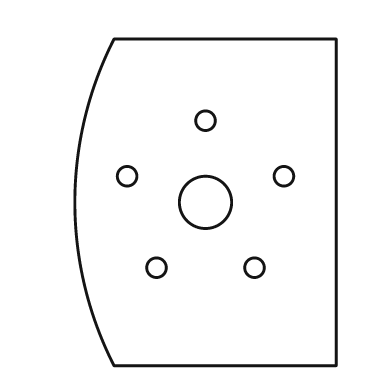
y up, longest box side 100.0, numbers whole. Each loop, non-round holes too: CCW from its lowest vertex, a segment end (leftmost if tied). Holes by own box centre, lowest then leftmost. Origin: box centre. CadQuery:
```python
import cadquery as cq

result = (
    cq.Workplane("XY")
    .moveTo(-28.0, -50.0)
    .lineTo(40.0, -50.0)
    .lineTo(40.0, 50.0)
    .lineTo(-28.0, 50.0)
    .threePointArc((-40.0, 0.0), (-28.0, -50.0))
    .close()
    .moveTo(-15.0, -20.0)
    .circle(3.0)
    .moveTo(15.0, -20.0)
    .circle(3.0)
    .moveTo(0.0, 0.0)
    .circle(8.0)
    .moveTo(-24.0, 8.0)
    .circle(3.0)
    .moveTo(24.0, 8.0)
    .circle(3.0)
    .moveTo(0.0, 25.0)
    .circle(3.0)
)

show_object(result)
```